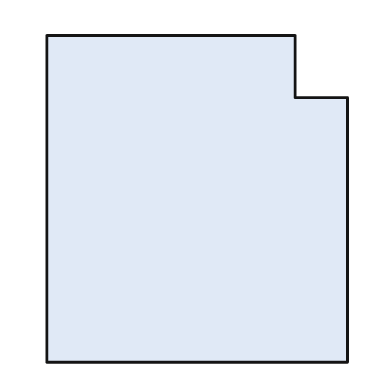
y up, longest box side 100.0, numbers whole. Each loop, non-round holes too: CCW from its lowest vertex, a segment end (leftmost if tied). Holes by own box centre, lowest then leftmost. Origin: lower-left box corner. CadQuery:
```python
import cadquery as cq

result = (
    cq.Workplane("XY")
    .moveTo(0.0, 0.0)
    .lineTo(92.0, 0.0)
    .lineTo(92.0, 81.0)
    .lineTo(76.0, 81.0)
    .lineTo(76.0, 100.0)
    .lineTo(0.0, 100.0)
    .close()
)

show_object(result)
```